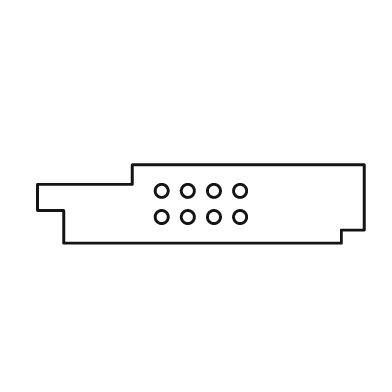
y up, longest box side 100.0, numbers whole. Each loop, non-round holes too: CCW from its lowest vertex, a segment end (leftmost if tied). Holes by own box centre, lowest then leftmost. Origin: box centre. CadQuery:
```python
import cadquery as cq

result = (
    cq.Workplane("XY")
    .moveTo(-42.0, -12.0)
    .lineTo(43.0, -12.0)
    .lineTo(43.0, -8.0)
    .lineTo(50.0, -8.0)
    .lineTo(50.0, 12.0)
    .lineTo(-21.0, 12.0)
    .lineTo(-21.0, 6.0)
    .lineTo(-50.0, 6.0)
    .lineTo(-50.0, -2.0)
    .lineTo(-42.0, -2.0)
    .close()
    .moveTo(-12.0, -4.0)
    .circle(2.0)
    .moveTo(-4.0, -4.0)
    .circle(2.0)
    .moveTo(4.0, -4.0)
    .circle(2.0)
    .moveTo(12.0, -4.0)
    .circle(2.0)
    .moveTo(-12.0, 4.0)
    .circle(2.0)
    .moveTo(-4.0, 4.0)
    .circle(2.0)
    .moveTo(4.0, 4.0)
    .circle(2.0)
    .moveTo(12.0, 4.0)
    .circle(2.0)
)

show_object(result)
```